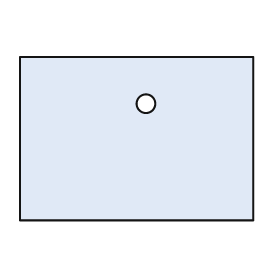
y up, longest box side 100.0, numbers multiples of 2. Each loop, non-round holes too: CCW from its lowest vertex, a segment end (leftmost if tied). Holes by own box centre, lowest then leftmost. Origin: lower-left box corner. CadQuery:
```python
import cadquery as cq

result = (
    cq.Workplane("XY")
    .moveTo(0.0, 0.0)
    .lineTo(100.0, 0.0)
    .lineTo(100.0, 70.0)
    .lineTo(0.0, 70.0)
    .close()
    .moveTo(54.0, 50.0)
    .circle(4.0)
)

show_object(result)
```